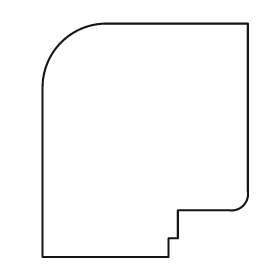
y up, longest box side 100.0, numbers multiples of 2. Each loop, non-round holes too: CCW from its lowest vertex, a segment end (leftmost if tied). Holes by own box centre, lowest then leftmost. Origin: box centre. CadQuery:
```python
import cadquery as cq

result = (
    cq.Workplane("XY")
    .moveTo(-44.0, -50.0)
    .lineTo(10.0, -50.0)
    .lineTo(10.0, -42.0)
    .lineTo(14.0, -42.0)
    .lineTo(14.0, -30.0)
    .lineTo(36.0, -30.0)
    .threePointArc((42.0, -28.0), (44.0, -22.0))
    .lineTo(44.0, 50.0)
    .lineTo(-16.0, 50.0)
    .threePointArc((-36.0, 42.0), (-44.0, 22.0))
    .close()
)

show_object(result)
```